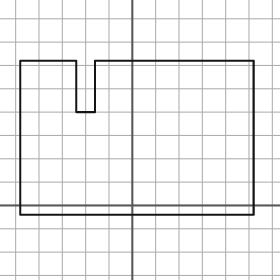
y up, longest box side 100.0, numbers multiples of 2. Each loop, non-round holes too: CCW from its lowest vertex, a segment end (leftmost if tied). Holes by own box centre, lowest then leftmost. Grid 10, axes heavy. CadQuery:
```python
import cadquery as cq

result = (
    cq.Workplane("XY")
    .moveTo(-48.0, -4.0)
    .lineTo(52.0, -4.0)
    .lineTo(52.0, 62.0)
    .lineTo(-16.0, 62.0)
    .lineTo(-16.0, 40.0)
    .lineTo(-24.0, 40.0)
    .lineTo(-24.0, 62.0)
    .lineTo(-48.0, 62.0)
    .close()
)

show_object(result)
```